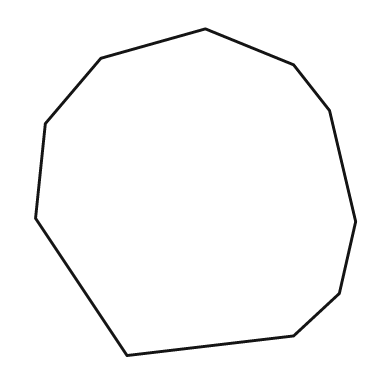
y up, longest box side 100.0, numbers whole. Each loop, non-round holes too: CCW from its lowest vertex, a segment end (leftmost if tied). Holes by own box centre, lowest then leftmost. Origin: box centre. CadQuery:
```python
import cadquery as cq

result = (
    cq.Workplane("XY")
    .moveTo(-21.0, -50.0)
    .lineTo(30.0, -44.0)
    .lineTo(44.0, -31.0)
    .lineTo(49.0, -9.0)
    .lineTo(41.0, 25.0)
    .lineTo(30.0, 39.0)
    .lineTo(3.0, 50.0)
    .lineTo(-29.0, 41.0)
    .lineTo(-46.0, 21.0)
    .lineTo(-49.0, -8.0)
    .close()
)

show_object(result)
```